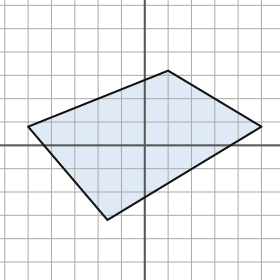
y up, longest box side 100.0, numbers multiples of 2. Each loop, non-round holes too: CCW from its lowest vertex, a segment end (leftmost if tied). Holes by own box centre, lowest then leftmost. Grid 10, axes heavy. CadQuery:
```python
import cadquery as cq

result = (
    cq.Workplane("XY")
    .moveTo(-16.0, -32.0)
    .lineTo(50.0, 8.0)
    .lineTo(10.0, 32.0)
    .lineTo(-50.0, 8.0)
    .close()
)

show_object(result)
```